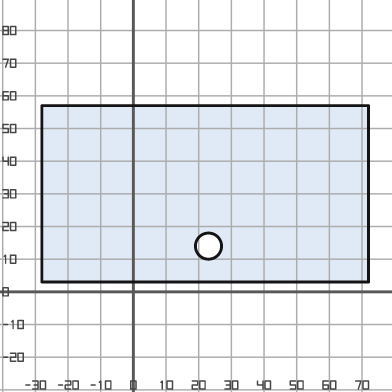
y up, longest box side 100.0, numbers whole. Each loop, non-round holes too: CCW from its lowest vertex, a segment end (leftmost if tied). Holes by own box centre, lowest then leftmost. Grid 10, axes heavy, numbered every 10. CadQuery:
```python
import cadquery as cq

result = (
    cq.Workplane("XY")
    .moveTo(-28.0, 3.0)
    .lineTo(72.0, 3.0)
    .lineTo(72.0, 57.0)
    .lineTo(-28.0, 57.0)
    .close()
    .moveTo(23.0, 14.0)
    .circle(4.0)
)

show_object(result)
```